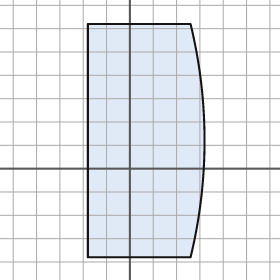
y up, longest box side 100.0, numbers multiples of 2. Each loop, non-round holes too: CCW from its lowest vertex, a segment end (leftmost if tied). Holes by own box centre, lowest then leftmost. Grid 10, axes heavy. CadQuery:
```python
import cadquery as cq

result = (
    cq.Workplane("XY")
    .moveTo(-18.0, -38.0)
    .lineTo(26.0, -38.0)
    .threePointArc((32.0, 12.0), (26.0, 62.0))
    .lineTo(-18.0, 62.0)
    .close()
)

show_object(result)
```